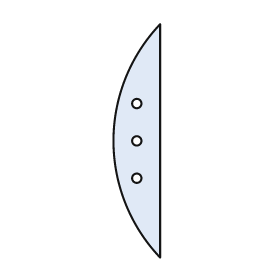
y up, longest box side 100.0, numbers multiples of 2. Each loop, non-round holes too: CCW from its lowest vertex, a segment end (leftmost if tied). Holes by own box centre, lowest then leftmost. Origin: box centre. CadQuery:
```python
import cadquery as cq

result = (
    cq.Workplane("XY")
    .moveTo(10.0, -50.0)
    .lineTo(10.0, 50.0)
    .threePointArc((-10.0, 0.0), (10.0, -50.0))
    .close()
    .moveTo(0.0, -16.0)
    .circle(2.0)
    .moveTo(0.0, 0.0)
    .circle(2.0)
    .moveTo(0.0, 16.0)
    .circle(2.0)
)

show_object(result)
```